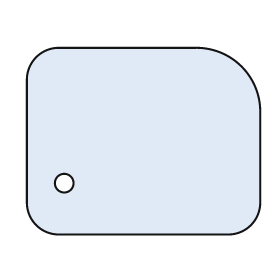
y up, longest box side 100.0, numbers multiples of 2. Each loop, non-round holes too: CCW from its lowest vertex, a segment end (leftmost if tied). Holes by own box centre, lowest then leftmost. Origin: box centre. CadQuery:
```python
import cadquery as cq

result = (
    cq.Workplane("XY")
    .moveTo(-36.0, -40.0)
    .lineTo(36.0, -40.0)
    .threePointArc((46.0, -36.0), (50.0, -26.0))
    .lineTo(50.0, 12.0)
    .threePointArc((42.0, 32.0), (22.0, 40.0))
    .lineTo(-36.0, 40.0)
    .threePointArc((-46.0, 36.0), (-50.0, 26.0))
    .lineTo(-50.0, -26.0)
    .threePointArc((-46.0, -36.0), (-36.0, -40.0))
    .close()
    .moveTo(-34.0, -18.0)
    .circle(4.0)
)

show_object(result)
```